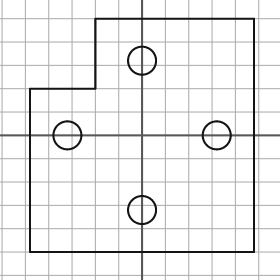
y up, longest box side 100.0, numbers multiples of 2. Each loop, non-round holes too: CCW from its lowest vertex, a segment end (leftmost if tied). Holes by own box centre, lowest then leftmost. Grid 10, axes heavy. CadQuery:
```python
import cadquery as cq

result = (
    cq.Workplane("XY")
    .moveTo(-48.0, -50.0)
    .lineTo(48.0, -50.0)
    .lineTo(48.0, 50.0)
    .lineTo(-20.0, 50.0)
    .lineTo(-20.0, 20.0)
    .lineTo(-48.0, 20.0)
    .close()
    .moveTo(0.0, -32.0)
    .circle(6.0)
    .moveTo(-32.0, 0.0)
    .circle(6.0)
    .moveTo(32.0, 0.0)
    .circle(6.0)
    .moveTo(0.0, 32.0)
    .circle(6.0)
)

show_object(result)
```